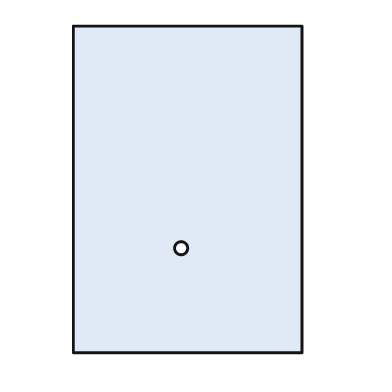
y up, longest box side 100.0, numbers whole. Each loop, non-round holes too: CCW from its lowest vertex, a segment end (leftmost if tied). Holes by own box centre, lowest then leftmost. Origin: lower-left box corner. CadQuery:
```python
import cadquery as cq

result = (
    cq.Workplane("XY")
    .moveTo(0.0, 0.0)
    .lineTo(70.0, 0.0)
    .lineTo(70.0, 100.0)
    .lineTo(0.0, 100.0)
    .close()
    .moveTo(33.0, 32.0)
    .circle(2.0)
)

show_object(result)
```